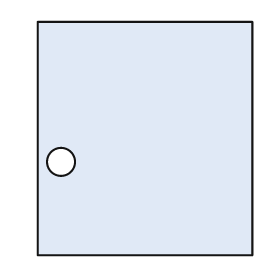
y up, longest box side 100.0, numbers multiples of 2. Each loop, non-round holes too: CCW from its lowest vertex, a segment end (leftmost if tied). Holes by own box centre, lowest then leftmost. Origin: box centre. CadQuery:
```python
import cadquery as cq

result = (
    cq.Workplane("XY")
    .moveTo(-46.0, -50.0)
    .lineTo(46.0, -50.0)
    .lineTo(46.0, 50.0)
    .lineTo(-46.0, 50.0)
    .close()
    .moveTo(-36.0, -10.0)
    .circle(6.0)
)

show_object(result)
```